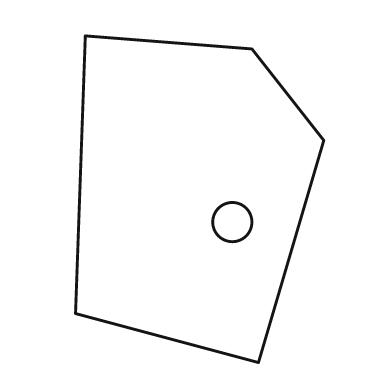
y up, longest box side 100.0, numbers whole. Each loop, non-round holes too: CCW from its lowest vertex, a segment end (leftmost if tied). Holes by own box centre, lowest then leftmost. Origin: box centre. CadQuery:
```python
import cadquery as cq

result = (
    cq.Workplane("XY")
    .moveTo(18.0, -50.0)
    .lineTo(38.0, 18.0)
    .lineTo(16.0, 46.0)
    .lineTo(-35.0, 50.0)
    .lineTo(-38.0, -35.0)
    .close()
    .moveTo(10.0, -7.0)
    .circle(6.0)
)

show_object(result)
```